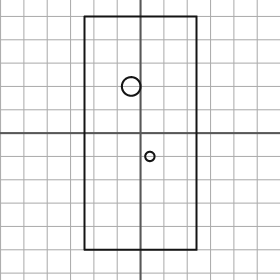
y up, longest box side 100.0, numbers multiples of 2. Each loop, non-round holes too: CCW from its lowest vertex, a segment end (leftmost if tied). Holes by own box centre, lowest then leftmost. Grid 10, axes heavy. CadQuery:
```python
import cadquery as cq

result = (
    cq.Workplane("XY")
    .moveTo(-24.0, -50.0)
    .lineTo(24.0, -50.0)
    .lineTo(24.0, 50.0)
    .lineTo(-24.0, 50.0)
    .close()
    .moveTo(4.0, -10.0)
    .circle(2.0)
    .moveTo(-4.0, 20.0)
    .circle(4.0)
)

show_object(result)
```